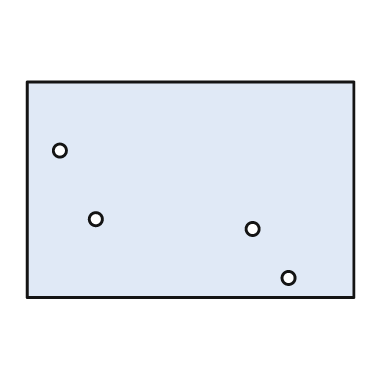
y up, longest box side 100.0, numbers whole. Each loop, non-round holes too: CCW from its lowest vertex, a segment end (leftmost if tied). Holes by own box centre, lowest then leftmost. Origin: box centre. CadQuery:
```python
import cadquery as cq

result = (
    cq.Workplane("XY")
    .moveTo(-50.0, -33.0)
    .lineTo(50.0, -33.0)
    .lineTo(50.0, 33.0)
    .lineTo(-50.0, 33.0)
    .close()
    .moveTo(30.0, -27.0)
    .circle(2.0)
    .moveTo(19.0, -12.0)
    .circle(2.0)
    .moveTo(-29.0, -9.0)
    .circle(2.0)
    .moveTo(-40.0, 12.0)
    .circle(2.0)
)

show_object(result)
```